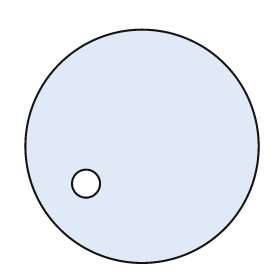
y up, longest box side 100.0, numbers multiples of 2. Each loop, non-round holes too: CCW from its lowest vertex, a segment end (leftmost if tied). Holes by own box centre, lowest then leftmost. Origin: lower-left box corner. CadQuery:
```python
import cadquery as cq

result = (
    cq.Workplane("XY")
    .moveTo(50.0, 50.0)
    .circle(50.0)
    .moveTo(26.0, 34.0)
    .circle(6.0)
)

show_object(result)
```